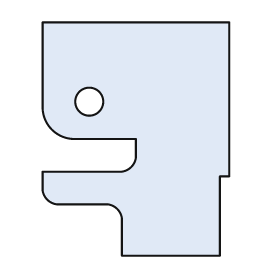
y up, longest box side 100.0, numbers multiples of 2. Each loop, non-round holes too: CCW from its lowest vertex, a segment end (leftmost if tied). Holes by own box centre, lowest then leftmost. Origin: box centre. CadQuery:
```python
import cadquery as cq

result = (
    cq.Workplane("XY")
    .moveTo(-6.0, -50.0)
    .lineTo(36.0, -50.0)
    .lineTo(36.0, -16.0)
    .lineTo(40.0, -16.0)
    .lineTo(40.0, 50.0)
    .lineTo(-40.0, 50.0)
    .lineTo(-40.0, 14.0)
    .threePointArc((-36.0, 4.0), (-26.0, 0.0))
    .lineTo(0.0, 0.0)
    .lineTo(0.0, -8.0)
    .threePointArc((-2.0, -12.0), (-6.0, -14.0))
    .lineTo(-40.0, -14.0)
    .lineTo(-40.0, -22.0)
    .threePointArc((-38.0, -26.0), (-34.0, -28.0))
    .lineTo(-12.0, -28.0)
    .threePointArc((-8.0, -30.0), (-6.0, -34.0))
    .close()
    .moveTo(-20.0, 16.0)
    .circle(6.0)
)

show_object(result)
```